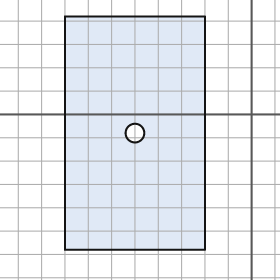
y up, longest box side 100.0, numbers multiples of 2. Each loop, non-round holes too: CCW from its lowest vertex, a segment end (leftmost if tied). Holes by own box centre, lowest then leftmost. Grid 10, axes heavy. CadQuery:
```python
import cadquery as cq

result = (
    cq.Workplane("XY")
    .moveTo(-80.0, -58.0)
    .lineTo(-20.0, -58.0)
    .lineTo(-20.0, 42.0)
    .lineTo(-80.0, 42.0)
    .close()
    .moveTo(-50.0, -8.0)
    .circle(4.0)
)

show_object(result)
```